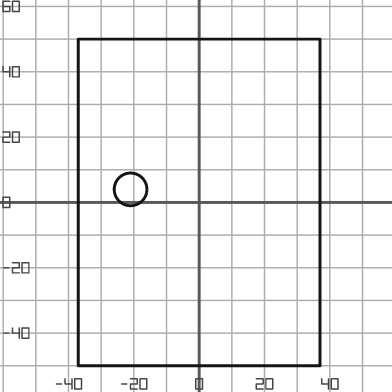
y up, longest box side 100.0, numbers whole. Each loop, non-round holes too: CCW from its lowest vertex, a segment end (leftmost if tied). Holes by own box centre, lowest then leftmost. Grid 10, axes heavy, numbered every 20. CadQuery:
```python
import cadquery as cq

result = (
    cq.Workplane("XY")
    .moveTo(-37.0, -50.0)
    .lineTo(37.0, -50.0)
    .lineTo(37.0, 50.0)
    .lineTo(-37.0, 50.0)
    .close()
    .moveTo(-21.0, 4.0)
    .circle(5.0)
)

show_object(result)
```